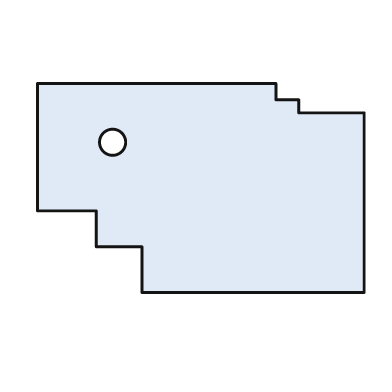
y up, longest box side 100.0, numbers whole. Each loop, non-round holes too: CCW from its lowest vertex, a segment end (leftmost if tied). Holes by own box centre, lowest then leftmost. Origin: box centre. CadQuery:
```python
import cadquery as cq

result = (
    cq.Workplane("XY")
    .moveTo(-18.0, -32.0)
    .lineTo(50.0, -32.0)
    .lineTo(50.0, 23.0)
    .lineTo(30.0, 23.0)
    .lineTo(30.0, 27.0)
    .lineTo(23.0, 27.0)
    .lineTo(23.0, 32.0)
    .lineTo(-50.0, 32.0)
    .lineTo(-50.0, -7.0)
    .lineTo(-32.0, -7.0)
    .lineTo(-32.0, -18.0)
    .lineTo(-18.0, -18.0)
    .close()
    .moveTo(-27.0, 14.0)
    .circle(4.0)
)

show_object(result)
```